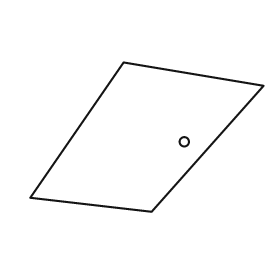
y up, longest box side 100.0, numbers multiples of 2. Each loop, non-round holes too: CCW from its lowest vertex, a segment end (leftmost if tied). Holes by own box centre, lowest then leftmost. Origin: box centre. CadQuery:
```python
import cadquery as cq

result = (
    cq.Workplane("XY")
    .moveTo(2.0, -32.0)
    .lineTo(50.0, 22.0)
    .lineTo(-10.0, 32.0)
    .lineTo(-50.0, -26.0)
    .close()
    .moveTo(16.0, -2.0)
    .circle(2.0)
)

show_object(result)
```